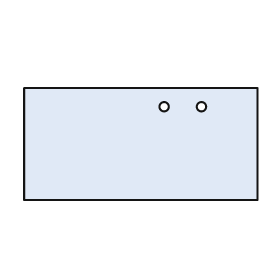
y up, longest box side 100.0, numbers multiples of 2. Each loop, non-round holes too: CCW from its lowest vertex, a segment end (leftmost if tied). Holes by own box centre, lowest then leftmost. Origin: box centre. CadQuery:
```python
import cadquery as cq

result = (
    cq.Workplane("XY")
    .moveTo(-50.0, -24.0)
    .lineTo(50.0, -24.0)
    .lineTo(50.0, 24.0)
    .lineTo(-50.0, 24.0)
    .close()
    .moveTo(10.0, 16.0)
    .circle(2.0)
    .moveTo(26.0, 16.0)
    .circle(2.0)
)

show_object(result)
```